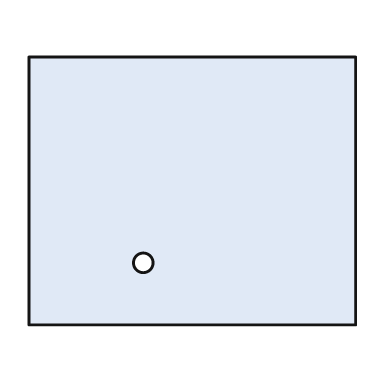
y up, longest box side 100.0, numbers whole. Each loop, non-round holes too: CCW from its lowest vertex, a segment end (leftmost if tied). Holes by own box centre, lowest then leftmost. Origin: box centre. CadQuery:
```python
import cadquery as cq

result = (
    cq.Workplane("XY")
    .moveTo(-50.0, -41.0)
    .lineTo(50.0, -41.0)
    .lineTo(50.0, 41.0)
    .lineTo(-50.0, 41.0)
    .close()
    .moveTo(-15.0, -22.0)
    .circle(3.0)
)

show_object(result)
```